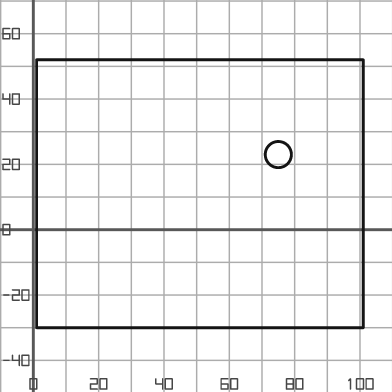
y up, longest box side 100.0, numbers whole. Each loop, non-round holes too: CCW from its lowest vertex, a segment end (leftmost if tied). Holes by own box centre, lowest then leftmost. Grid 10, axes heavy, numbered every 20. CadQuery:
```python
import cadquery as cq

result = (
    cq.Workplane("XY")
    .moveTo(1.0, -30.0)
    .lineTo(101.0, -30.0)
    .lineTo(101.0, 52.0)
    .lineTo(1.0, 52.0)
    .close()
    .moveTo(75.0, 23.0)
    .circle(4.0)
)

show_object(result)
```